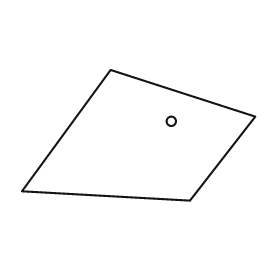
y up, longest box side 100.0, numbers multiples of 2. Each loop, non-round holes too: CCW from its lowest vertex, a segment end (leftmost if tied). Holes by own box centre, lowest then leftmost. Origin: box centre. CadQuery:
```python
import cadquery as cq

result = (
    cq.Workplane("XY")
    .moveTo(22.0, -28.0)
    .lineTo(50.0, 8.0)
    .lineTo(-12.0, 28.0)
    .lineTo(-50.0, -24.0)
    .close()
    .moveTo(14.0, 6.0)
    .circle(2.0)
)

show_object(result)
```